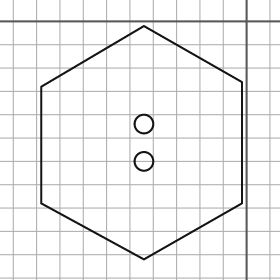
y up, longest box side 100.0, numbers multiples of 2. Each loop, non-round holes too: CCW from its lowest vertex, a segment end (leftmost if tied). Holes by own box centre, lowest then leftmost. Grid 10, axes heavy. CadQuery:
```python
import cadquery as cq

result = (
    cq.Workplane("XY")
    .moveTo(-44.0, -102.0)
    .lineTo(-2.0, -78.0)
    .lineTo(-2.0, -26.0)
    .lineTo(-44.0, -2.0)
    .lineTo(-88.0, -28.0)
    .lineTo(-88.0, -78.0)
    .close()
    .moveTo(-44.0, -60.0)
    .circle(4.0)
    .moveTo(-44.0, -44.0)
    .circle(4.0)
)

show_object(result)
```